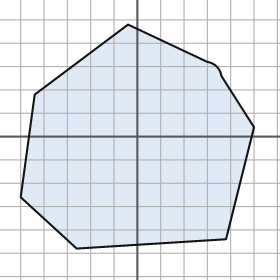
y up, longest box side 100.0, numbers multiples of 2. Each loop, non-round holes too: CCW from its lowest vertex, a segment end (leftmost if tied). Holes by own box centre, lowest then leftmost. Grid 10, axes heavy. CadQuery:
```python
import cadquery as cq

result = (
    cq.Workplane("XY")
    .moveTo(-26.0, -48.0)
    .lineTo(38.0, -44.0)
    .lineTo(50.0, 4.0)
    .lineTo(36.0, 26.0)
    .threePointArc((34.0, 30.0), (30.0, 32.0))
    .lineTo(-4.0, 48.0)
    .lineTo(-44.0, 18.0)
    .lineTo(-50.0, -26.0)
    .close()
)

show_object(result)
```